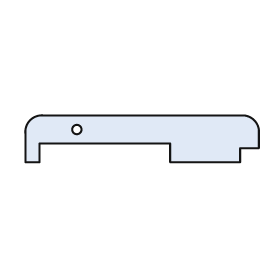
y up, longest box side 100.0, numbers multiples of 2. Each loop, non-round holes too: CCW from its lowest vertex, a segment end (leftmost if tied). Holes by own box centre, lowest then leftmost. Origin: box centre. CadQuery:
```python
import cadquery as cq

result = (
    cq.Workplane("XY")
    .moveTo(-50.0, -10.0)
    .lineTo(-44.0, -10.0)
    .lineTo(-44.0, -2.0)
    .lineTo(12.0, -2.0)
    .lineTo(12.0, -10.0)
    .lineTo(42.0, -10.0)
    .lineTo(42.0, -4.0)
    .lineTo(50.0, -4.0)
    .lineTo(50.0, 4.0)
    .threePointArc((48.0, 8.0), (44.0, 10.0))
    .lineTo(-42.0, 10.0)
    .threePointArc((-48.0, 8.0), (-50.0, 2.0))
    .close()
    .moveTo(-28.0, 4.0)
    .circle(2.0)
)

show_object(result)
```